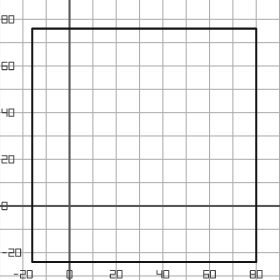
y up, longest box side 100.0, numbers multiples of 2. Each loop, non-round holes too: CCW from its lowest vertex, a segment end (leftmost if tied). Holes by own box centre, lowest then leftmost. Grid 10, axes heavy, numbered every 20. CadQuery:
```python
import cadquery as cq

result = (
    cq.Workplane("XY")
    .moveTo(-16.0, -24.0)
    .lineTo(80.0, -24.0)
    .lineTo(80.0, 76.0)
    .lineTo(-16.0, 76.0)
    .close()
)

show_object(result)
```